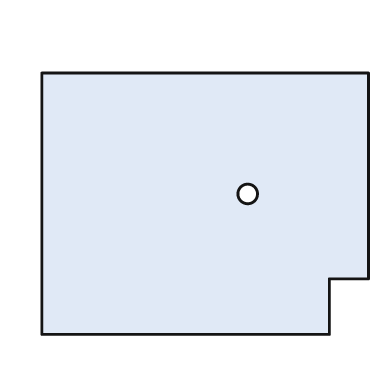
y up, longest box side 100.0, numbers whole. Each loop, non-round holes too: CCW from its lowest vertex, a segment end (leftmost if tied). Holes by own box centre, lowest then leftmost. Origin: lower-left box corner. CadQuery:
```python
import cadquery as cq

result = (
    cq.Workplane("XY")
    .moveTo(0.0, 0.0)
    .lineTo(88.0, 0.0)
    .lineTo(88.0, 17.0)
    .lineTo(100.0, 17.0)
    .lineTo(100.0, 80.0)
    .lineTo(0.0, 80.0)
    .close()
    .moveTo(63.0, 43.0)
    .circle(3.0)
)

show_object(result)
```